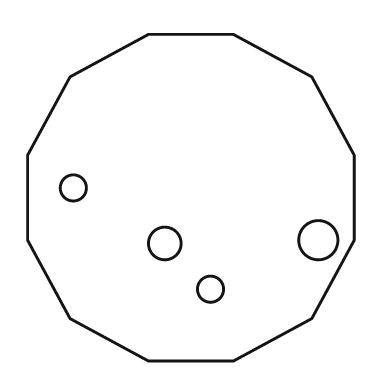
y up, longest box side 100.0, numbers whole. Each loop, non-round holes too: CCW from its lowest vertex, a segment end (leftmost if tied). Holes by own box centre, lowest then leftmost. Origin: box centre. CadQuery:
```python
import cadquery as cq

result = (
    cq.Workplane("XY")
    .moveTo(-13.0, -50.0)
    .lineTo(13.0, -50.0)
    .lineTo(37.0, -37.0)
    .lineTo(50.0, -13.0)
    .lineTo(50.0, 13.0)
    .lineTo(37.0, 37.0)
    .lineTo(13.0, 50.0)
    .lineTo(-13.0, 50.0)
    .lineTo(-37.0, 37.0)
    .lineTo(-50.0, 13.0)
    .lineTo(-50.0, -13.0)
    .lineTo(-37.0, -37.0)
    .close()
    .moveTo(6.0, -28.0)
    .circle(4.0)
    .moveTo(-8.0, -14.0)
    .circle(5.0)
    .moveTo(39.0, -13.0)
    .circle(6.0)
    .moveTo(-36.0, 3.0)
    .circle(4.0)
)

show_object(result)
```